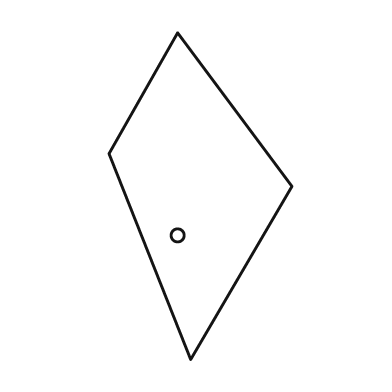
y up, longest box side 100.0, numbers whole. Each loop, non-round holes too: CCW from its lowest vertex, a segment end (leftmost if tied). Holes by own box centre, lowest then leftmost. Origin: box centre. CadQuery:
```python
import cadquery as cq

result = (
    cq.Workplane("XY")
    .moveTo(-3.0, -50.0)
    .lineTo(28.0, 3.0)
    .lineTo(-7.0, 50.0)
    .lineTo(-28.0, 13.0)
    .close()
    .moveTo(-7.0, -12.0)
    .circle(2.0)
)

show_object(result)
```